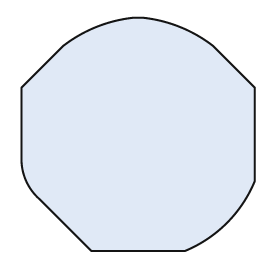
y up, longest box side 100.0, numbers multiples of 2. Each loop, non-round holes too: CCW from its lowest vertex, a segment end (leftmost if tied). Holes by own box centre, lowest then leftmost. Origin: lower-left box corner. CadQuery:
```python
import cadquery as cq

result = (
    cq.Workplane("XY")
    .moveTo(30.0, 0.0)
    .lineTo(70.0, 0.0)
    .threePointArc((88.0, 12.0), (100.0, 30.0))
    .lineTo(100.0, 70.0)
    .lineTo(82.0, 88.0)
    .threePointArc((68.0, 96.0), (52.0, 100.0))
    .lineTo(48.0, 100.0)
    .threePointArc((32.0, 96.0), (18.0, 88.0))
    .lineTo(0.0, 70.0)
    .lineTo(0.0, 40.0)
    .threePointArc((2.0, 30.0), (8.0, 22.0))
    .close()
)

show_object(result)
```